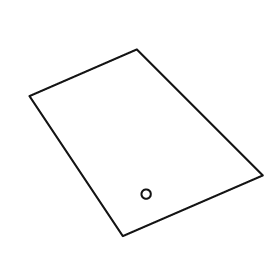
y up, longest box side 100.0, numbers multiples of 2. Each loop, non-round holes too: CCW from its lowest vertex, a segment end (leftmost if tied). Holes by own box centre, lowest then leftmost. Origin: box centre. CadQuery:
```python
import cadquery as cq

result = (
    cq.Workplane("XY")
    .moveTo(-10.0, -40.0)
    .lineTo(50.0, -14.0)
    .lineTo(-4.0, 40.0)
    .lineTo(-50.0, 20.0)
    .close()
    .moveTo(0.0, -22.0)
    .circle(2.0)
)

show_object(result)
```